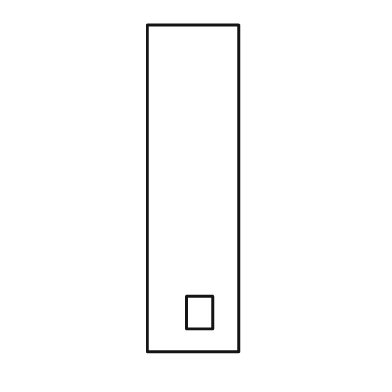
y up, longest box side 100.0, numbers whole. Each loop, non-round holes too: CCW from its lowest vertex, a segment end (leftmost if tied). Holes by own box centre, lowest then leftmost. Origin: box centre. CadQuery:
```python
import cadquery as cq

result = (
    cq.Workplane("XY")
    .moveTo(-14.0, -50.0)
    .lineTo(14.0, -50.0)
    .lineTo(14.0, 50.0)
    .lineTo(-14.0, 50.0)
    .close()
    .moveTo(-2.0, -43.0)
    .lineTo(6.0, -43.0)
    .lineTo(6.0, -33.0)
    .lineTo(-2.0, -33.0)
    .close()
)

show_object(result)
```